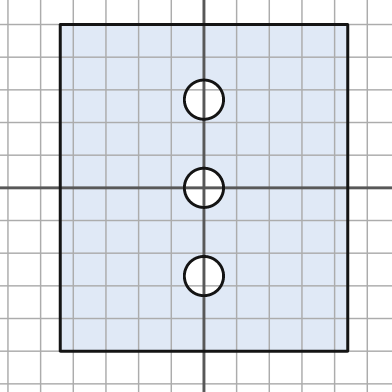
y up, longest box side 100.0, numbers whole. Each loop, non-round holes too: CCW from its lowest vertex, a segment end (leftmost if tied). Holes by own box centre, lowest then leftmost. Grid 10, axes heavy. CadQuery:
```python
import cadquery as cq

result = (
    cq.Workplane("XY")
    .moveTo(-44.0, -50.0)
    .lineTo(44.0, -50.0)
    .lineTo(44.0, 50.0)
    .lineTo(-44.0, 50.0)
    .close()
    .moveTo(0.0, -27.0)
    .circle(6.0)
    .moveTo(0.0, 0.0)
    .circle(6.0)
    .moveTo(0.0, 27.0)
    .circle(6.0)
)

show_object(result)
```